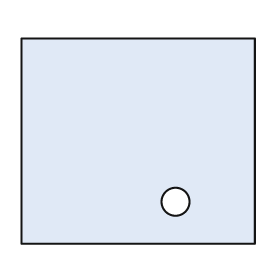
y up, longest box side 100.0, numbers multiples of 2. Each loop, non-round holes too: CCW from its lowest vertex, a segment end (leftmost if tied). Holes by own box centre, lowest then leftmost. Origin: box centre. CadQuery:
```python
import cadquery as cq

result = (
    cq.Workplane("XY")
    .moveTo(-50.0, -44.0)
    .lineTo(50.0, -44.0)
    .lineTo(50.0, 44.0)
    .lineTo(-50.0, 44.0)
    .close()
    .moveTo(16.0, -26.0)
    .circle(6.0)
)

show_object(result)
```